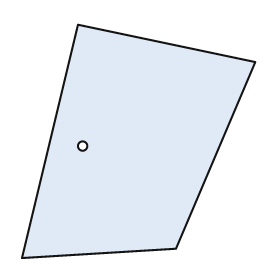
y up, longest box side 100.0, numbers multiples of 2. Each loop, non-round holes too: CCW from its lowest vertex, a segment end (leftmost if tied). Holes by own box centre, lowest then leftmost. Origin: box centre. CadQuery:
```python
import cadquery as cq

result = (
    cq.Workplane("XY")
    .moveTo(-50.0, -50.0)
    .lineTo(16.0, -46.0)
    .lineTo(50.0, 34.0)
    .lineTo(-26.0, 50.0)
    .close()
    .moveTo(-24.0, -2.0)
    .circle(2.0)
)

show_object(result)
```